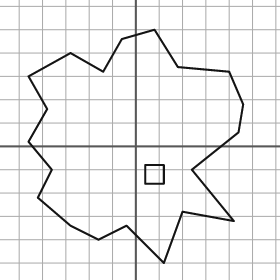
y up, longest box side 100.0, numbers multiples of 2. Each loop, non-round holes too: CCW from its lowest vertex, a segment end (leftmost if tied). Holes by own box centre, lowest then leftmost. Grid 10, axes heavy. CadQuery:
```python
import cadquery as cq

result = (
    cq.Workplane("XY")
    .moveTo(12.0, -50.0)
    .lineTo(20.0, -28.0)
    .lineTo(42.0, -32.0)
    .lineTo(24.0, -10.0)
    .lineTo(44.0, 6.0)
    .lineTo(46.0, 18.0)
    .lineTo(40.0, 32.0)
    .lineTo(18.0, 34.0)
    .lineTo(8.0, 50.0)
    .lineTo(-6.0, 46.0)
    .lineTo(-14.0, 32.0)
    .lineTo(-28.0, 40.0)
    .lineTo(-46.0, 30.0)
    .lineTo(-38.0, 16.0)
    .lineTo(-46.0, 2.0)
    .lineTo(-36.0, -10.0)
    .lineTo(-42.0, -22.0)
    .lineTo(-28.0, -34.0)
    .lineTo(-16.0, -40.0)
    .lineTo(-4.0, -34.0)
    .close()
    .moveTo(4.0, -16.0)
    .lineTo(12.0, -16.0)
    .lineTo(12.0, -8.0)
    .lineTo(4.0, -8.0)
    .close()
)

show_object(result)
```